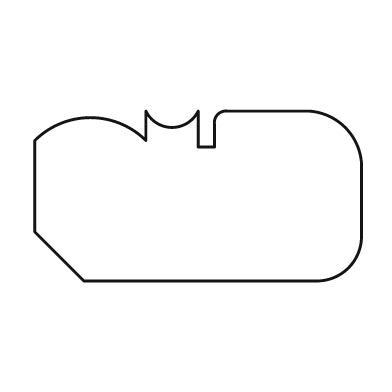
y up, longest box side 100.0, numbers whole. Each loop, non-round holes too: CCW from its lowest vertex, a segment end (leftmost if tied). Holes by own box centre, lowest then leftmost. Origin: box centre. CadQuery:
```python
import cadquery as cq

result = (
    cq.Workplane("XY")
    .moveTo(-35.0, -26.0)
    .lineTo(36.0, -26.0)
    .threePointArc((46.0, -22.0), (50.0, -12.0))
    .lineTo(50.0, 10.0)
    .threePointArc((45.0, 21.0), (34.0, 26.0))
    .lineTo(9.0, 26.0)
    .threePointArc((6.0, 25.0), (5.0, 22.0))
    .lineTo(5.0, 15.0)
    .lineTo(0.0, 15.0)
    .lineTo(0.0, 26.0)
    .threePointArc((-8.0, 21.0), (-16.0, 26.0))
    .lineTo(-16.0, 17.0)
    .threePointArc((-33.0, 24.0), (-50.0, 17.0))
    .lineTo(-50.0, -11.0)
    .close()
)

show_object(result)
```